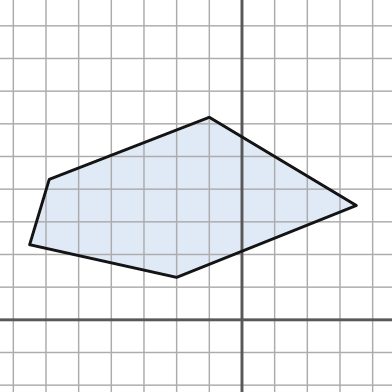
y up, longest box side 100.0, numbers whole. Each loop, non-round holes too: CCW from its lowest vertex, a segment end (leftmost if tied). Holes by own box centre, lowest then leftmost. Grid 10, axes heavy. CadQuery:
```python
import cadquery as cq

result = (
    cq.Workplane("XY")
    .moveTo(-20.0, 13.0)
    .lineTo(35.0, 35.0)
    .lineTo(-10.0, 62.0)
    .lineTo(-59.0, 43.0)
    .lineTo(-65.0, 23.0)
    .close()
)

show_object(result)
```